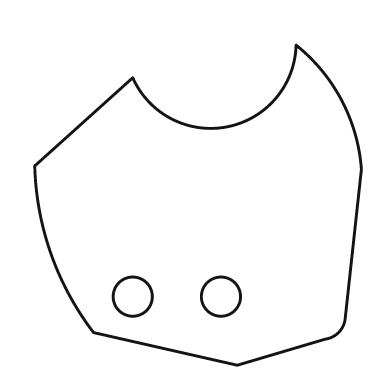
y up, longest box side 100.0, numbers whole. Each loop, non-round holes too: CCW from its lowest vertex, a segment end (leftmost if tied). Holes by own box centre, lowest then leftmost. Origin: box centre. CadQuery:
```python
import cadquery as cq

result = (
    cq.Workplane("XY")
    .moveTo(12.0, -49.0)
    .lineTo(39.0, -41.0)
    .threePointArc((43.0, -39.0), (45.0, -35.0))
    .lineTo(50.0, 11.0)
    .threePointArc((44.0, 32.0), (30.0, 49.0))
    .threePointArc((9.0, 24.0), (-20.0, 39.0))
    .lineTo(-50.0, 12.0)
    .threePointArc((-45.0, -15.0), (-32.0, -39.0))
    .close()
    .moveTo(-20.0, -28.0)
    .circle(6.0)
    .moveTo(7.0, -28.0)
    .circle(6.0)
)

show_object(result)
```